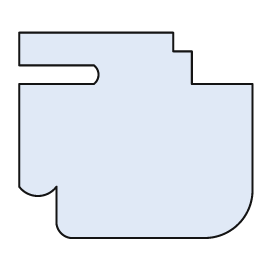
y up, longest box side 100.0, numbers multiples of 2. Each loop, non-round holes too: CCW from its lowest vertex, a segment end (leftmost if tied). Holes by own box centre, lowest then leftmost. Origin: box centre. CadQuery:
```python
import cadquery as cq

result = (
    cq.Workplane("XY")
    .moveTo(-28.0, -44.0)
    .lineTo(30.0, -44.0)
    .threePointArc((44.0, -38.0), (50.0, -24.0))
    .lineTo(50.0, 22.0)
    .lineTo(24.0, 22.0)
    .lineTo(24.0, 36.0)
    .lineTo(16.0, 36.0)
    .lineTo(16.0, 44.0)
    .lineTo(-50.0, 44.0)
    .lineTo(-50.0, 30.0)
    .lineTo(-18.0, 30.0)
    .threePointArc((-16.0, 26.0), (-18.0, 22.0))
    .lineTo(-50.0, 22.0)
    .lineTo(-50.0, -22.0)
    .threePointArc((-42.0, -26.0), (-34.0, -22.0))
    .lineTo(-34.0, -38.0)
    .threePointArc((-32.0, -42.0), (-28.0, -44.0))
    .close()
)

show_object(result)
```